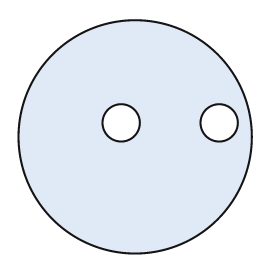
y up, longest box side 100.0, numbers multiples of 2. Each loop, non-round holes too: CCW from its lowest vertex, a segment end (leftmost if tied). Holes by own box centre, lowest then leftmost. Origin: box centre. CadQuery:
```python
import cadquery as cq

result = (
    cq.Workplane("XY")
    .moveTo(0.0, 0.0)
    .circle(50.0)
    .moveTo(-6.0, 6.0)
    .circle(8.0)
    .moveTo(36.0, 6.0)
    .circle(8.0)
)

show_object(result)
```